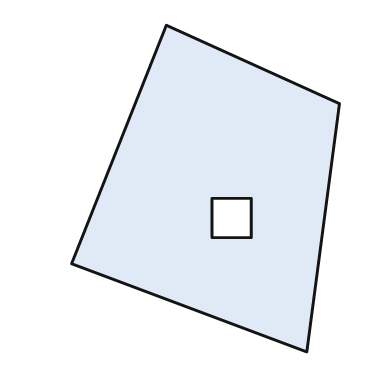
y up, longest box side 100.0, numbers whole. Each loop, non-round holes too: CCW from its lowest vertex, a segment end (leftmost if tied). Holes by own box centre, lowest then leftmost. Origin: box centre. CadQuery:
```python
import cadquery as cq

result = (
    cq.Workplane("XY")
    .moveTo(31.0, -50.0)
    .lineTo(41.0, 26.0)
    .lineTo(-12.0, 50.0)
    .lineTo(-41.0, -23.0)
    .close()
    .moveTo(2.0, -15.0)
    .lineTo(14.0, -15.0)
    .lineTo(14.0, -3.0)
    .lineTo(2.0, -3.0)
    .close()
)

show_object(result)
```